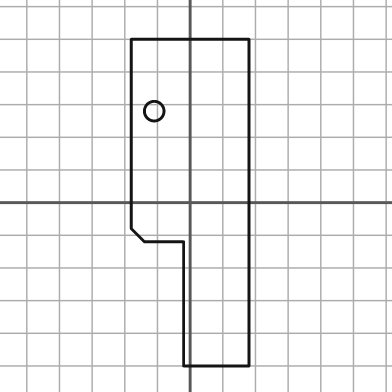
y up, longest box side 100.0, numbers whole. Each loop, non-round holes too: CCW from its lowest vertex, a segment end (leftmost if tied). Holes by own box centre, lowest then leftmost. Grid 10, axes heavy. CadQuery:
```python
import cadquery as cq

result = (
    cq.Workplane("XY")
    .moveTo(-2.0, -50.0)
    .lineTo(18.0, -50.0)
    .lineTo(18.0, 50.0)
    .lineTo(-18.0, 50.0)
    .lineTo(-18.0, -8.0)
    .lineTo(-14.0, -12.0)
    .lineTo(-2.0, -12.0)
    .close()
    .moveTo(-11.0, 28.0)
    .circle(3.0)
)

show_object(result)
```